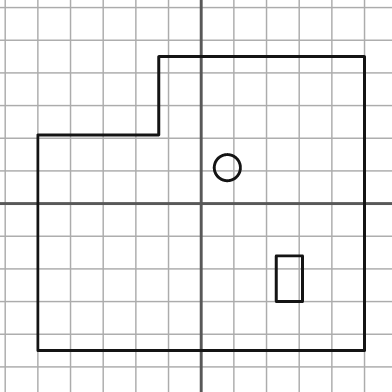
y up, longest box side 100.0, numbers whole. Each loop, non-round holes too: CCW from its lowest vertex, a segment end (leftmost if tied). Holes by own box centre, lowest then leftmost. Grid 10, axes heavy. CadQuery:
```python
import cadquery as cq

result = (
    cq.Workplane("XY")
    .moveTo(-50.0, -45.0)
    .lineTo(50.0, -45.0)
    .lineTo(50.0, 45.0)
    .lineTo(-13.0, 45.0)
    .lineTo(-13.0, 21.0)
    .lineTo(-50.0, 21.0)
    .close()
    .moveTo(23.0, -30.0)
    .lineTo(31.0, -30.0)
    .lineTo(31.0, -16.0)
    .lineTo(23.0, -16.0)
    .close()
    .moveTo(8.0, 11.0)
    .circle(4.0)
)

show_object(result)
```